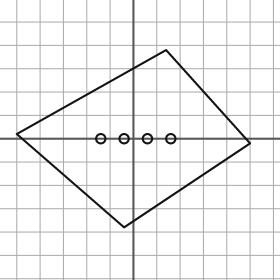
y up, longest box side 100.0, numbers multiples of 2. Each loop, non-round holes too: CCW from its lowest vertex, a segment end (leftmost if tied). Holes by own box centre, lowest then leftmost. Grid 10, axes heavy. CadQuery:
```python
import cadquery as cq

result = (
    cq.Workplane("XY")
    .moveTo(-4.0, -38.0)
    .lineTo(50.0, -2.0)
    .lineTo(14.0, 38.0)
    .lineTo(-50.0, 2.0)
    .close()
    .moveTo(-14.0, 0.0)
    .circle(2.0)
    .moveTo(-4.0, 0.0)
    .circle(2.0)
    .moveTo(6.0, 0.0)
    .circle(2.0)
    .moveTo(16.0, 0.0)
    .circle(2.0)
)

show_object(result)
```